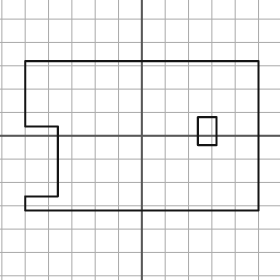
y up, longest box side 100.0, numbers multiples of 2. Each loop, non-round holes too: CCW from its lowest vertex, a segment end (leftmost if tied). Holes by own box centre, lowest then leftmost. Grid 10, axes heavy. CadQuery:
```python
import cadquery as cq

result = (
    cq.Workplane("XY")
    .moveTo(-50.0, -32.0)
    .lineTo(50.0, -32.0)
    .lineTo(50.0, 32.0)
    .lineTo(-50.0, 32.0)
    .lineTo(-50.0, 4.0)
    .lineTo(-36.0, 4.0)
    .lineTo(-36.0, -26.0)
    .lineTo(-50.0, -26.0)
    .close()
    .moveTo(24.0, -4.0)
    .lineTo(32.0, -4.0)
    .lineTo(32.0, 8.0)
    .lineTo(24.0, 8.0)
    .close()
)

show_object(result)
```